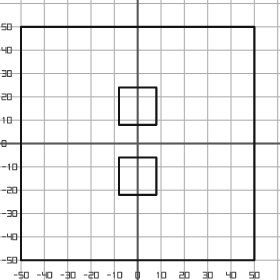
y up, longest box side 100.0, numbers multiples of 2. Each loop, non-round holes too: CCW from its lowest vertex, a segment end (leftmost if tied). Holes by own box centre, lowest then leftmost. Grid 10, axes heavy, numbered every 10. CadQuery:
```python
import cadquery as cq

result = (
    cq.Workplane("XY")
    .moveTo(-50.0, -50.0)
    .lineTo(50.0, -50.0)
    .lineTo(50.0, 50.0)
    .lineTo(-50.0, 50.0)
    .close()
    .moveTo(-8.0, -22.0)
    .lineTo(8.0, -22.0)
    .lineTo(8.0, -6.0)
    .lineTo(-8.0, -6.0)
    .close()
    .moveTo(-8.0, 8.0)
    .lineTo(8.0, 8.0)
    .lineTo(8.0, 24.0)
    .lineTo(-8.0, 24.0)
    .close()
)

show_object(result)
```